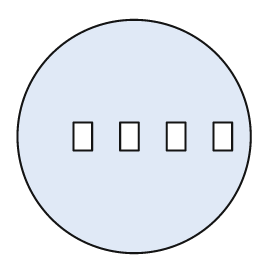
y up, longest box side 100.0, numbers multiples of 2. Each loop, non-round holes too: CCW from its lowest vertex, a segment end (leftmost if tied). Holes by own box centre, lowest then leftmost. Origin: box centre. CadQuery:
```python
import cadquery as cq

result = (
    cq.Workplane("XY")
    .moveTo(0.0, 0.0)
    .circle(50.0)
    .moveTo(-26.0, -6.0)
    .lineTo(-18.0, -6.0)
    .lineTo(-18.0, 6.0)
    .lineTo(-26.0, 6.0)
    .close()
    .moveTo(-6.0, -6.0)
    .lineTo(2.0, -6.0)
    .lineTo(2.0, 6.0)
    .lineTo(-6.0, 6.0)
    .close()
    .moveTo(14.0, -6.0)
    .lineTo(22.0, -6.0)
    .lineTo(22.0, 6.0)
    .lineTo(14.0, 6.0)
    .close()
    .moveTo(34.0, -6.0)
    .lineTo(42.0, -6.0)
    .lineTo(42.0, 6.0)
    .lineTo(34.0, 6.0)
    .close()
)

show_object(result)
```